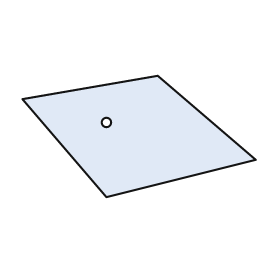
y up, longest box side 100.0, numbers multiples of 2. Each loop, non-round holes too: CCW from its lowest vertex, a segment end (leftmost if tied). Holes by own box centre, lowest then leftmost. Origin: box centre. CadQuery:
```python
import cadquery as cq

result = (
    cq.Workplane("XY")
    .moveTo(-14.0, -26.0)
    .lineTo(50.0, -10.0)
    .lineTo(8.0, 26.0)
    .lineTo(-50.0, 16.0)
    .close()
    .moveTo(-14.0, 6.0)
    .circle(2.0)
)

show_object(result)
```